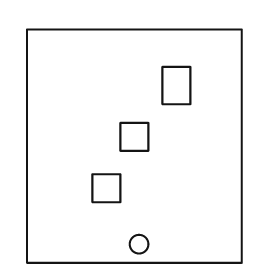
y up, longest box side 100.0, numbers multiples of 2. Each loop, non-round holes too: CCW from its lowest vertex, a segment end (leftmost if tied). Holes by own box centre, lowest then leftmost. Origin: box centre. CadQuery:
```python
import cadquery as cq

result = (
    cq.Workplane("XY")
    .moveTo(-46.0, -50.0)
    .lineTo(46.0, -50.0)
    .lineTo(46.0, 50.0)
    .lineTo(-46.0, 50.0)
    .close()
    .moveTo(2.0, -42.0)
    .circle(4.0)
    .moveTo(-18.0, -24.0)
    .lineTo(-6.0, -24.0)
    .lineTo(-6.0, -12.0)
    .lineTo(-18.0, -12.0)
    .close()
    .moveTo(-6.0, -2.0)
    .lineTo(6.0, -2.0)
    .lineTo(6.0, 10.0)
    .lineTo(-6.0, 10.0)
    .close()
    .moveTo(12.0, 18.0)
    .lineTo(24.0, 18.0)
    .lineTo(24.0, 34.0)
    .lineTo(12.0, 34.0)
    .close()
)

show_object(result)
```